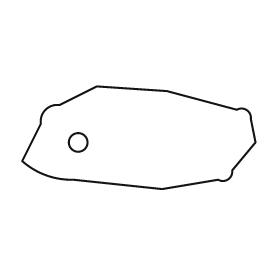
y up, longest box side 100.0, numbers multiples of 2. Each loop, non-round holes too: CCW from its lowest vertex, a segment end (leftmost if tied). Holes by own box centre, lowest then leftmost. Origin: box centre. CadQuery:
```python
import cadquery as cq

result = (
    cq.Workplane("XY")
    .moveTo(10.0, -22.0)
    .lineTo(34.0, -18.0)
    .threePointArc((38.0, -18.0), (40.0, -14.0))
    .lineTo(50.0, -2.0)
    .lineTo(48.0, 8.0)
    .threePointArc((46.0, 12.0), (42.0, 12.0))
    .lineTo(12.0, 20.0)
    .lineTo(-18.0, 22.0)
    .lineTo(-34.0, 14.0)
    .threePointArc((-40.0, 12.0), (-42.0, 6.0))
    .lineTo(-50.0, -10.0)
    .threePointArc((-40.0, -16.0), (-28.0, -18.0))
    .close()
    .moveTo(-26.0, -2.0)
    .circle(4.0)
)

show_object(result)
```